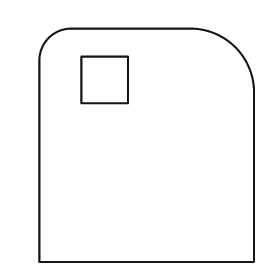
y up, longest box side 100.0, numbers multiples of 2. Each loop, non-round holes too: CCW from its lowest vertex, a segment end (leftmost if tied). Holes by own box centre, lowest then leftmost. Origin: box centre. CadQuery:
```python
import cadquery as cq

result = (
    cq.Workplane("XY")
    .moveTo(-46.0, -50.0)
    .lineTo(46.0, -50.0)
    .lineTo(46.0, 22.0)
    .threePointArc((38.0, 42.0), (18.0, 50.0))
    .lineTo(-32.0, 50.0)
    .threePointArc((-42.0, 46.0), (-46.0, 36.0))
    .close()
    .moveTo(-28.0, 18.0)
    .lineTo(-8.0, 18.0)
    .lineTo(-8.0, 38.0)
    .lineTo(-28.0, 38.0)
    .close()
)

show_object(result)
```